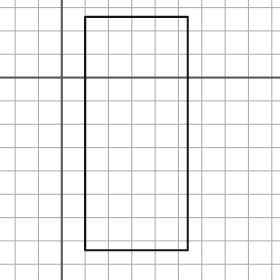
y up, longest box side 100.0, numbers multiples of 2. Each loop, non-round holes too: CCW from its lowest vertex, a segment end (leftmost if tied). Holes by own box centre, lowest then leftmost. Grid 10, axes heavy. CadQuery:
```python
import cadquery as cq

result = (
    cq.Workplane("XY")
    .moveTo(10.0, -74.0)
    .lineTo(54.0, -74.0)
    .lineTo(54.0, 26.0)
    .lineTo(10.0, 26.0)
    .close()
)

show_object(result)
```